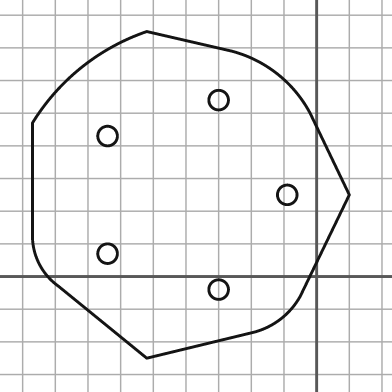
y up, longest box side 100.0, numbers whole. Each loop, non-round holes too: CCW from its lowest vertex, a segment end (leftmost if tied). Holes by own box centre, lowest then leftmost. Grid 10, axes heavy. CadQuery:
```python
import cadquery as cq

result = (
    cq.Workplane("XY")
    .moveTo(-52.0, -25.0)
    .lineTo(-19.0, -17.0)
    .threePointArc((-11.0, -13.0), (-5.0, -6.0))
    .lineTo(10.0, 25.0)
    .lineTo(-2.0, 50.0)
    .threePointArc((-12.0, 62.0), (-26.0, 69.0))
    .lineTo(-52.0, 75.0)
    .threePointArc((-72.0, 64.0), (-87.0, 47.0))
    .lineTo(-87.0, 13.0)
    .threePointArc((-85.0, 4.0), (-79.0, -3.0))
    .close()
    .moveTo(-30.0, -4.0)
    .circle(3.0)
    .moveTo(-64.0, 7.0)
    .circle(3.0)
    .moveTo(-9.0, 25.0)
    .circle(3.0)
    .moveTo(-64.0, 43.0)
    .circle(3.0)
    .moveTo(-30.0, 54.0)
    .circle(3.0)
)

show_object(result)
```